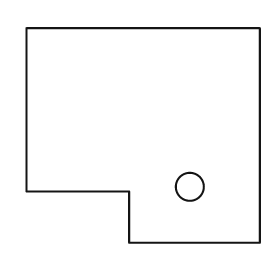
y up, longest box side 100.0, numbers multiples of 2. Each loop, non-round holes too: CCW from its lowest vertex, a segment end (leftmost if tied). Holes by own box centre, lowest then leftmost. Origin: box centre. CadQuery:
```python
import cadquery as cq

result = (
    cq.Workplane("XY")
    .moveTo(-6.0, -46.0)
    .lineTo(50.0, -46.0)
    .lineTo(50.0, 46.0)
    .lineTo(-50.0, 46.0)
    .lineTo(-50.0, -24.0)
    .lineTo(-6.0, -24.0)
    .close()
    .moveTo(20.0, -22.0)
    .circle(6.0)
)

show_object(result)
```